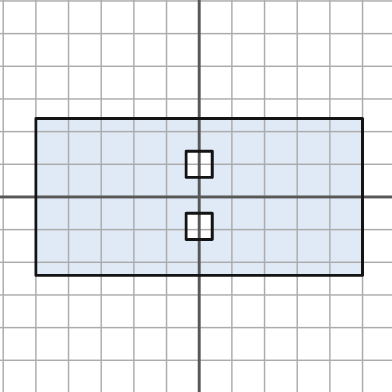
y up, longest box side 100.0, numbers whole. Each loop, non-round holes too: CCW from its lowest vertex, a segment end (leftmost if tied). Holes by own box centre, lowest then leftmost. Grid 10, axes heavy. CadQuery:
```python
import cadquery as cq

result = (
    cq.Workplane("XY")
    .moveTo(-50.0, -24.0)
    .lineTo(50.0, -24.0)
    .lineTo(50.0, 24.0)
    .lineTo(-50.0, 24.0)
    .close()
    .moveTo(-4.0, -13.0)
    .lineTo(4.0, -13.0)
    .lineTo(4.0, -5.0)
    .lineTo(-4.0, -5.0)
    .close()
    .moveTo(-4.0, 6.0)
    .lineTo(4.0, 6.0)
    .lineTo(4.0, 14.0)
    .lineTo(-4.0, 14.0)
    .close()
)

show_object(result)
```